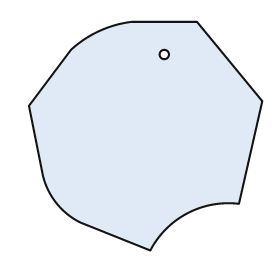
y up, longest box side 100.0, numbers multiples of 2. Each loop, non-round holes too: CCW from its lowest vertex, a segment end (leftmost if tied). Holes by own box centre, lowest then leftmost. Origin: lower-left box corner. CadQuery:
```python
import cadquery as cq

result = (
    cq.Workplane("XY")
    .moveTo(52.0, 0.0)
    .threePointArc((68.0, 16.0), (90.0, 20.0))
    .lineTo(100.0, 64.0)
    .lineTo(72.0, 98.0)
    .lineTo(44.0, 98.0)
    .threePointArc((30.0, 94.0), (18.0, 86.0))
    .lineTo(0.0, 62.0)
    .lineTo(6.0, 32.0)
    .threePointArc((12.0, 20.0), (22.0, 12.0))
    .close()
    .moveTo(58.0, 84.0)
    .circle(2.0)
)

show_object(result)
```